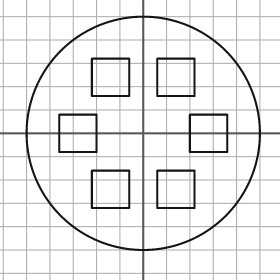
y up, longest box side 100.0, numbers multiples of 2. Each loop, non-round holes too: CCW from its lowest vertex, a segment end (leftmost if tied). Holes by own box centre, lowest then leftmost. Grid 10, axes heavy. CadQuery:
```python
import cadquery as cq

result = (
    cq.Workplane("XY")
    .moveTo(0.0, 0.0)
    .circle(50.0)
    .moveTo(-22.0, -32.0)
    .lineTo(-6.0, -32.0)
    .lineTo(-6.0, -16.0)
    .lineTo(-22.0, -16.0)
    .close()
    .moveTo(6.0, -32.0)
    .lineTo(22.0, -32.0)
    .lineTo(22.0, -16.0)
    .lineTo(6.0, -16.0)
    .close()
    .moveTo(-36.0, -8.0)
    .lineTo(-20.0, -8.0)
    .lineTo(-20.0, 8.0)
    .lineTo(-36.0, 8.0)
    .close()
    .moveTo(20.0, -8.0)
    .lineTo(36.0, -8.0)
    .lineTo(36.0, 8.0)
    .lineTo(20.0, 8.0)
    .close()
    .moveTo(-22.0, 16.0)
    .lineTo(-6.0, 16.0)
    .lineTo(-6.0, 32.0)
    .lineTo(-22.0, 32.0)
    .close()
    .moveTo(6.0, 16.0)
    .lineTo(22.0, 16.0)
    .lineTo(22.0, 32.0)
    .lineTo(6.0, 32.0)
    .close()
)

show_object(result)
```